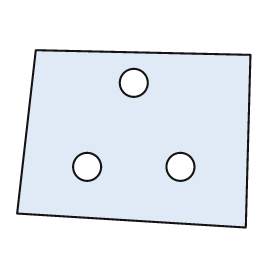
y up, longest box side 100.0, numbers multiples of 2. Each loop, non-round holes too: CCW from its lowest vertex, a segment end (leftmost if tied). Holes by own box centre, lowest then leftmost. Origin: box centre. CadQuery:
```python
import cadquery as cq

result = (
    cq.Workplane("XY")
    .moveTo(48.0, -38.0)
    .lineTo(50.0, 36.0)
    .lineTo(-42.0, 38.0)
    .lineTo(-50.0, -32.0)
    .close()
    .moveTo(-20.0, -12.0)
    .circle(6.0)
    .moveTo(20.0, -12.0)
    .circle(6.0)
    .moveTo(0.0, 24.0)
    .circle(6.0)
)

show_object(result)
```